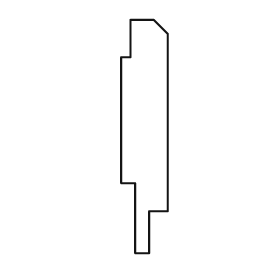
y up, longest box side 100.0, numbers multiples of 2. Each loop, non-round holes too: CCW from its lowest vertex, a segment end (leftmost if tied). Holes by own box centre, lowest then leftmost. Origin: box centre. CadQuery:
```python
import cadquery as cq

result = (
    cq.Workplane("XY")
    .moveTo(-4.0, -50.0)
    .lineTo(2.0, -50.0)
    .lineTo(2.0, -32.0)
    .lineTo(10.0, -32.0)
    .lineTo(10.0, 44.0)
    .lineTo(4.0, 50.0)
    .lineTo(-6.0, 50.0)
    .lineTo(-6.0, 34.0)
    .lineTo(-10.0, 34.0)
    .lineTo(-10.0, -20.0)
    .lineTo(-4.0, -20.0)
    .close()
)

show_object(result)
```